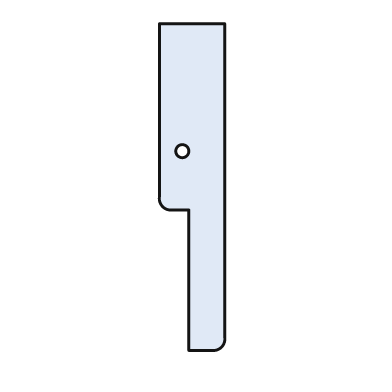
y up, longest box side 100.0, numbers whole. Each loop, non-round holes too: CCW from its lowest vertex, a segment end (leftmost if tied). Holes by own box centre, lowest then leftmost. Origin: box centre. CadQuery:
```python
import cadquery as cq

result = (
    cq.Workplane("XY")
    .moveTo(-1.0, -50.0)
    .lineTo(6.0, -50.0)
    .threePointArc((9.0, -49.0), (10.0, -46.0))
    .lineTo(10.0, 50.0)
    .lineTo(-10.0, 50.0)
    .lineTo(-10.0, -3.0)
    .threePointArc((-9.0, -6.0), (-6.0, -7.0))
    .lineTo(-1.0, -7.0)
    .close()
    .moveTo(-3.0, 11.0)
    .circle(2.0)
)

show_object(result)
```